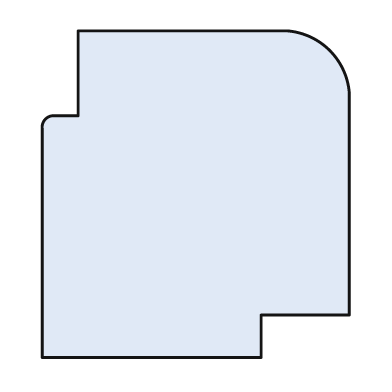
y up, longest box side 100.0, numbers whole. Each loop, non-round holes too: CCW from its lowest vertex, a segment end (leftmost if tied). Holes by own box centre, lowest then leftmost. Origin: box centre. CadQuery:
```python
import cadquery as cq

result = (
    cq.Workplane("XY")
    .moveTo(-47.0, -50.0)
    .lineTo(20.0, -50.0)
    .lineTo(20.0, -37.0)
    .lineTo(47.0, -37.0)
    .lineTo(47.0, 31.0)
    .threePointArc((41.0, 44.0), (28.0, 50.0))
    .lineTo(-36.0, 50.0)
    .lineTo(-36.0, 24.0)
    .lineTo(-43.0, 24.0)
    .threePointArc((-46.0, 23.0), (-47.0, 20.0))
    .close()
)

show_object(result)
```